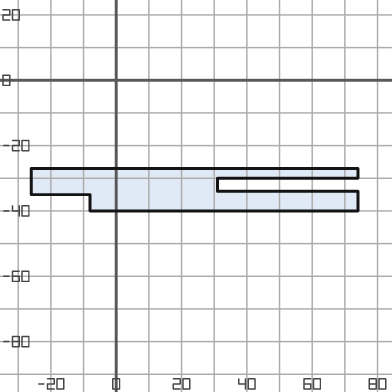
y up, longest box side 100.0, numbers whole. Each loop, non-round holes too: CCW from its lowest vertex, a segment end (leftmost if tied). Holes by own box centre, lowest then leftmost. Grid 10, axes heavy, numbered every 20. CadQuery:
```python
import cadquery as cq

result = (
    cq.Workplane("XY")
    .moveTo(-8.0, -40.0)
    .lineTo(74.0, -40.0)
    .lineTo(74.0, -34.0)
    .lineTo(31.0, -34.0)
    .lineTo(31.0, -30.0)
    .lineTo(74.0, -30.0)
    .lineTo(74.0, -27.0)
    .lineTo(-26.0, -27.0)
    .lineTo(-26.0, -35.0)
    .lineTo(-8.0, -35.0)
    .close()
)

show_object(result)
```